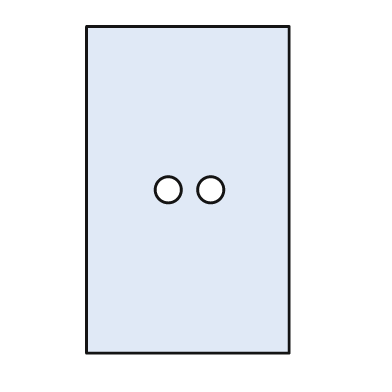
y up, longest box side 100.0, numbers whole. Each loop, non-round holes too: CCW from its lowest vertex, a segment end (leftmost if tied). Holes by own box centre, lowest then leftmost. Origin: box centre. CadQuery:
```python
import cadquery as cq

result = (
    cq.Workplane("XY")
    .moveTo(-31.0, -50.0)
    .lineTo(31.0, -50.0)
    .lineTo(31.0, 50.0)
    .lineTo(-31.0, 50.0)
    .close()
    .moveTo(-6.0, 0.0)
    .circle(4.0)
    .moveTo(7.0, 0.0)
    .circle(4.0)
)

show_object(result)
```